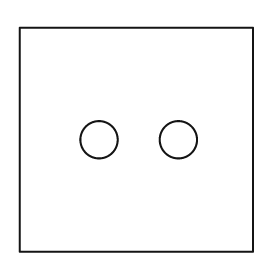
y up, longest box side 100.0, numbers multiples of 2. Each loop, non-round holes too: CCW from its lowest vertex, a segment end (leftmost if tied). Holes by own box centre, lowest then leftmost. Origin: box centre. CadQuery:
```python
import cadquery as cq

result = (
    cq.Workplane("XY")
    .moveTo(-50.0, -48.0)
    .lineTo(50.0, -48.0)
    .lineTo(50.0, 48.0)
    .lineTo(-50.0, 48.0)
    .close()
    .moveTo(-16.0, 0.0)
    .circle(8.0)
    .moveTo(18.0, 0.0)
    .circle(8.0)
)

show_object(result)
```